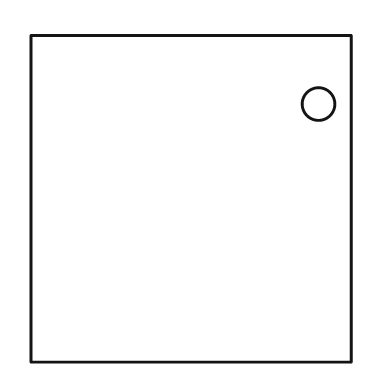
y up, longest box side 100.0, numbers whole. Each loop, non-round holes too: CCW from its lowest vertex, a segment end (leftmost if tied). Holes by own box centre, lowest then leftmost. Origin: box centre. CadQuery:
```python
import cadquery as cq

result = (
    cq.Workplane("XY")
    .moveTo(-49.0, -50.0)
    .lineTo(49.0, -50.0)
    .lineTo(49.0, 50.0)
    .lineTo(-49.0, 50.0)
    .close()
    .moveTo(39.0, 29.0)
    .circle(5.0)
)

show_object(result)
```